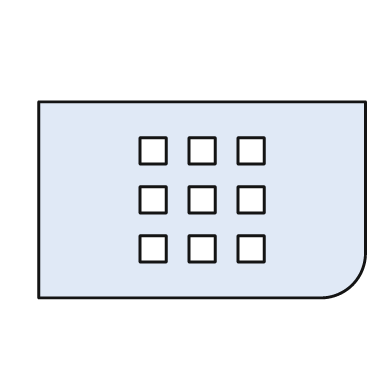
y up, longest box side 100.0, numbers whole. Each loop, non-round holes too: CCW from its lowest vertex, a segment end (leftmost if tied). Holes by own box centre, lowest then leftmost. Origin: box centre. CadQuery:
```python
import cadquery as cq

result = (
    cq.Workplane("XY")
    .moveTo(-50.0, -30.0)
    .lineTo(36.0, -30.0)
    .threePointArc((46.0, -26.0), (50.0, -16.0))
    .lineTo(50.0, 30.0)
    .lineTo(-50.0, 30.0)
    .close()
    .moveTo(-19.0, -19.0)
    .lineTo(-11.0, -19.0)
    .lineTo(-11.0, -11.0)
    .lineTo(-19.0, -11.0)
    .close()
    .moveTo(-4.0, -19.0)
    .lineTo(4.0, -19.0)
    .lineTo(4.0, -11.0)
    .lineTo(-4.0, -11.0)
    .close()
    .moveTo(11.0, -19.0)
    .lineTo(19.0, -19.0)
    .lineTo(19.0, -11.0)
    .lineTo(11.0, -11.0)
    .close()
    .moveTo(-19.0, -4.0)
    .lineTo(-11.0, -4.0)
    .lineTo(-11.0, 4.0)
    .lineTo(-19.0, 4.0)
    .close()
    .moveTo(-4.0, -4.0)
    .lineTo(4.0, -4.0)
    .lineTo(4.0, 4.0)
    .lineTo(-4.0, 4.0)
    .close()
    .moveTo(11.0, -4.0)
    .lineTo(19.0, -4.0)
    .lineTo(19.0, 4.0)
    .lineTo(11.0, 4.0)
    .close()
    .moveTo(-19.0, 11.0)
    .lineTo(-11.0, 11.0)
    .lineTo(-11.0, 19.0)
    .lineTo(-19.0, 19.0)
    .close()
    .moveTo(-4.0, 11.0)
    .lineTo(4.0, 11.0)
    .lineTo(4.0, 19.0)
    .lineTo(-4.0, 19.0)
    .close()
    .moveTo(11.0, 11.0)
    .lineTo(19.0, 11.0)
    .lineTo(19.0, 19.0)
    .lineTo(11.0, 19.0)
    .close()
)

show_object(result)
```